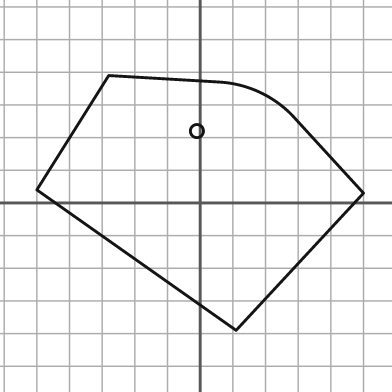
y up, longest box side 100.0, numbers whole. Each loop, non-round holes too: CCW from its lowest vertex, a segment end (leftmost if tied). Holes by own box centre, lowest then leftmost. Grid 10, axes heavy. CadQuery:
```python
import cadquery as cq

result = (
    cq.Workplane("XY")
    .moveTo(11.0, -39.0)
    .lineTo(50.0, 3.0)
    .lineTo(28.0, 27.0)
    .threePointArc((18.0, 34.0), (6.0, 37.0))
    .lineTo(-28.0, 39.0)
    .lineTo(-50.0, 4.0)
    .close()
    .moveTo(-1.0, 22.0)
    .circle(2.0)
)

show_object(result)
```